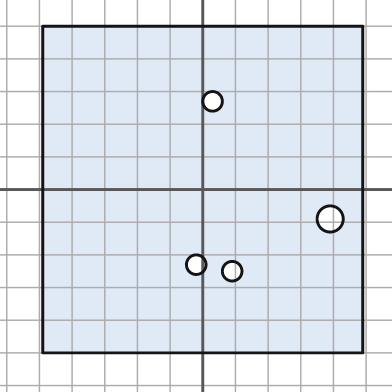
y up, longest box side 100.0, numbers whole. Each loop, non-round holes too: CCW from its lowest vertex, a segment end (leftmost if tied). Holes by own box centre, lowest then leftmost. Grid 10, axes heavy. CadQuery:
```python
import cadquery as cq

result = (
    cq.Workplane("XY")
    .moveTo(-49.0, -50.0)
    .lineTo(49.0, -50.0)
    .lineTo(49.0, 50.0)
    .lineTo(-49.0, 50.0)
    .close()
    .moveTo(9.0, -25.0)
    .circle(3.0)
    .moveTo(-2.0, -23.0)
    .circle(3.0)
    .moveTo(39.0, -9.0)
    .circle(4.0)
    .moveTo(3.0, 27.0)
    .circle(3.0)
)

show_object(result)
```